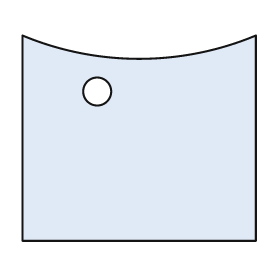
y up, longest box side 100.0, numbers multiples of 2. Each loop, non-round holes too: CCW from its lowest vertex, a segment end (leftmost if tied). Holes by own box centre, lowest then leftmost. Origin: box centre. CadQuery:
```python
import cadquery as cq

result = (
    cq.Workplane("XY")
    .moveTo(-50.0, -44.0)
    .lineTo(50.0, -44.0)
    .lineTo(50.0, 44.0)
    .threePointArc((0.0, 34.0), (-50.0, 44.0))
    .close()
    .moveTo(-18.0, 20.0)
    .circle(6.0)
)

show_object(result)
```